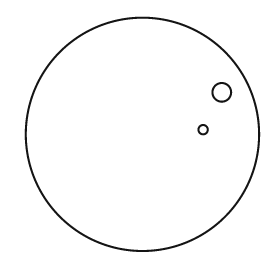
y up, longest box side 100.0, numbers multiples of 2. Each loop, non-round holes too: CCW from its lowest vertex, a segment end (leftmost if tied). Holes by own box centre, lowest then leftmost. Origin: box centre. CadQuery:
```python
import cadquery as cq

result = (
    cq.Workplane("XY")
    .moveTo(0.0, 0.0)
    .circle(50.0)
    .moveTo(26.0, 2.0)
    .circle(2.0)
    .moveTo(34.0, 18.0)
    .circle(4.0)
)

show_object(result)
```